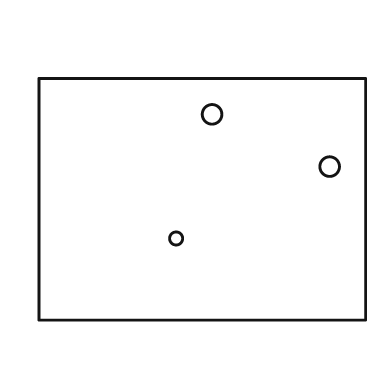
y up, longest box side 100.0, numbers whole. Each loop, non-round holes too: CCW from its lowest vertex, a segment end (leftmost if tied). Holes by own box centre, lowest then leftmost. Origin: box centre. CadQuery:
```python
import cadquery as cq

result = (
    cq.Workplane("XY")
    .moveTo(-50.0, -37.0)
    .lineTo(50.0, -37.0)
    .lineTo(50.0, 37.0)
    .lineTo(-50.0, 37.0)
    .close()
    .moveTo(-8.0, -12.0)
    .circle(2.0)
    .moveTo(39.0, 10.0)
    .circle(3.0)
    .moveTo(3.0, 26.0)
    .circle(3.0)
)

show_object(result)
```